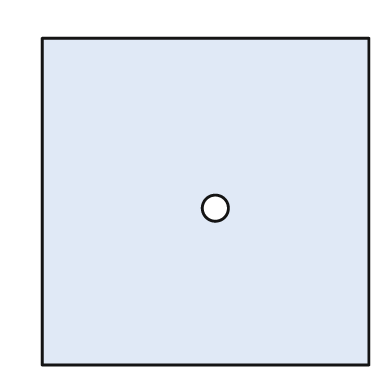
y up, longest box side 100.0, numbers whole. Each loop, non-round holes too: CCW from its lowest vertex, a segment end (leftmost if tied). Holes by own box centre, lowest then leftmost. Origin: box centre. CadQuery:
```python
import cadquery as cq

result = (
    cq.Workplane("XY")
    .moveTo(-50.0, -50.0)
    .lineTo(50.0, -50.0)
    .lineTo(50.0, 50.0)
    .lineTo(-50.0, 50.0)
    .close()
    .moveTo(3.0, -2.0)
    .circle(4.0)
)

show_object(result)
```